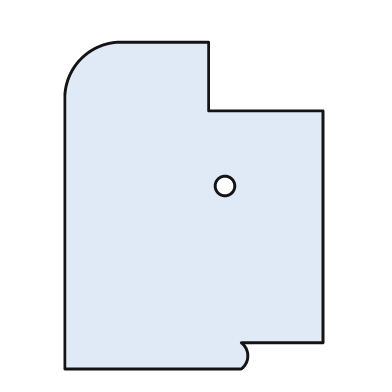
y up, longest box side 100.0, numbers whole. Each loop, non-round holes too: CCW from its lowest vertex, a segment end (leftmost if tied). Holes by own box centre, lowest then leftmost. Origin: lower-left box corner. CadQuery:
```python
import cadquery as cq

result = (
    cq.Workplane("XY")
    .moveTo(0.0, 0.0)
    .lineTo(54.0, 0.0)
    .threePointArc((56.0, 4.0), (54.0, 8.0))
    .lineTo(79.0, 8.0)
    .lineTo(79.0, 79.0)
    .lineTo(44.0, 79.0)
    .lineTo(44.0, 100.0)
    .lineTo(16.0, 100.0)
    .threePointArc((5.0, 95.0), (0.0, 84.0))
    .close()
    .moveTo(49.0, 56.0)
    .circle(3.0)
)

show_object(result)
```